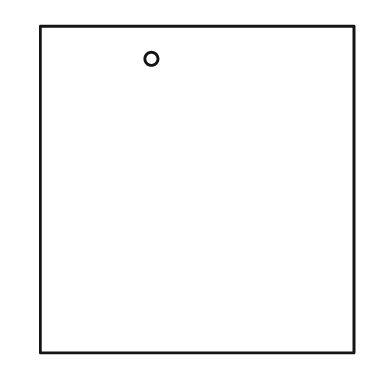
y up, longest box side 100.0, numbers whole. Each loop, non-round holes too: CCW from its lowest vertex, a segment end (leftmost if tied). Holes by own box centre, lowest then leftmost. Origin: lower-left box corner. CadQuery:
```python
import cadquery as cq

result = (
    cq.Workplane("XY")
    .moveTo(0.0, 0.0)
    .lineTo(96.0, 0.0)
    .lineTo(96.0, 100.0)
    .lineTo(0.0, 100.0)
    .close()
    .moveTo(34.0, 90.0)
    .circle(2.0)
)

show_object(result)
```